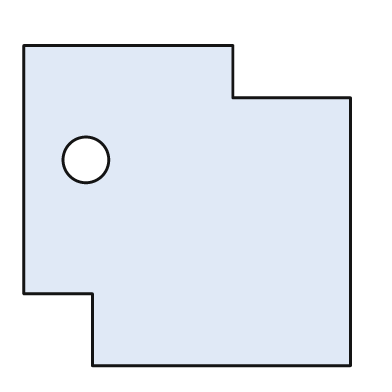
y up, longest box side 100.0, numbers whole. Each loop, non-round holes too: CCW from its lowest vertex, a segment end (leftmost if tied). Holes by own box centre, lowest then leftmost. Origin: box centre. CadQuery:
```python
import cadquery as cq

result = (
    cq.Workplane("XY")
    .moveTo(-29.0, -49.0)
    .lineTo(50.0, -49.0)
    .lineTo(50.0, 33.0)
    .lineTo(14.0, 33.0)
    .lineTo(14.0, 49.0)
    .lineTo(-50.0, 49.0)
    .lineTo(-50.0, -27.0)
    .lineTo(-29.0, -27.0)
    .close()
    .moveTo(-31.0, 14.0)
    .circle(7.0)
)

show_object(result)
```